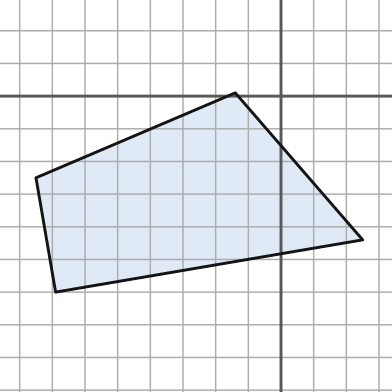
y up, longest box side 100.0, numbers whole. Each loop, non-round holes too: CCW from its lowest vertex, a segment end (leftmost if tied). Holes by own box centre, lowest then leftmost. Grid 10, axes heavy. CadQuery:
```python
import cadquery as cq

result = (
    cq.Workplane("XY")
    .moveTo(-69.0, -60.0)
    .lineTo(25.0, -44.0)
    .lineTo(-14.0, 1.0)
    .lineTo(-75.0, -25.0)
    .close()
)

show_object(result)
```